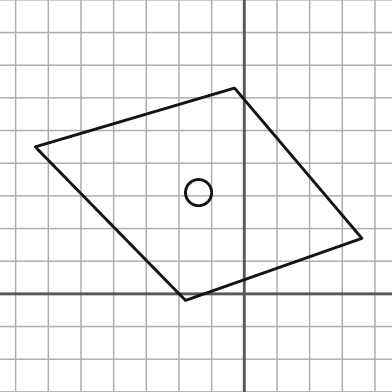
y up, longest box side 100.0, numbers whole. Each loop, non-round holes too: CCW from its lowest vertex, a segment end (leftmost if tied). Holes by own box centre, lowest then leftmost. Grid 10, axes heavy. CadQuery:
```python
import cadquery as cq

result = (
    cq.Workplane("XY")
    .moveTo(-18.0, -2.0)
    .lineTo(36.0, 17.0)
    .lineTo(-3.0, 63.0)
    .lineTo(-64.0, 45.0)
    .close()
    .moveTo(-14.0, 31.0)
    .circle(4.0)
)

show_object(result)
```